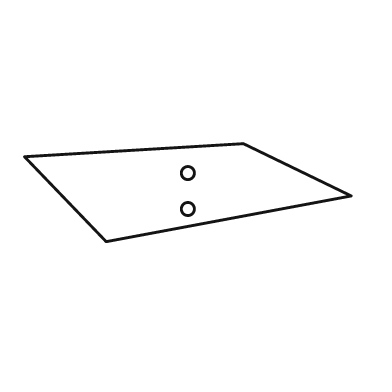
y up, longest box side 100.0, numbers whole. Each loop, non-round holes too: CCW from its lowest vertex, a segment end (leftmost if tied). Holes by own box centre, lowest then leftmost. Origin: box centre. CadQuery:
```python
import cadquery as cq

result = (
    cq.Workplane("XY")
    .moveTo(-25.0, -15.0)
    .lineTo(50.0, -1.0)
    .lineTo(17.0, 15.0)
    .lineTo(-50.0, 11.0)
    .close()
    .moveTo(0.0, -5.0)
    .circle(2.0)
    .moveTo(0.0, 6.0)
    .circle(2.0)
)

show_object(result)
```